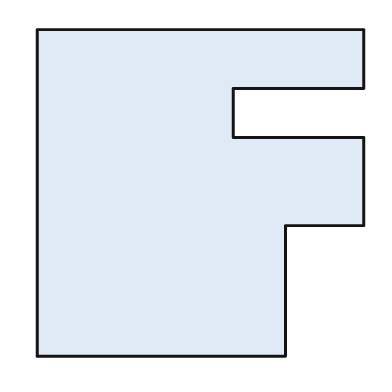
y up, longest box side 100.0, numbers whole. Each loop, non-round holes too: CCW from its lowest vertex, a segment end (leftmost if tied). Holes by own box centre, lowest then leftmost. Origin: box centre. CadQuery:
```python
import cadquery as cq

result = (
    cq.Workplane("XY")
    .moveTo(-50.0, -50.0)
    .lineTo(26.0, -50.0)
    .lineTo(26.0, -10.0)
    .lineTo(50.0, -10.0)
    .lineTo(50.0, 17.0)
    .lineTo(10.0, 17.0)
    .lineTo(10.0, 32.0)
    .lineTo(50.0, 32.0)
    .lineTo(50.0, 50.0)
    .lineTo(-50.0, 50.0)
    .close()
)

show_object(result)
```